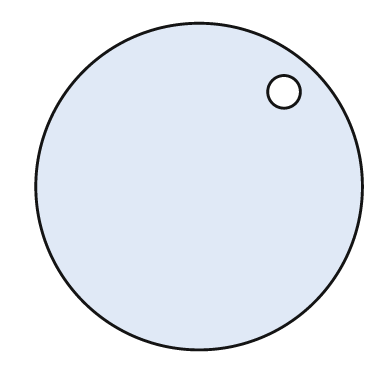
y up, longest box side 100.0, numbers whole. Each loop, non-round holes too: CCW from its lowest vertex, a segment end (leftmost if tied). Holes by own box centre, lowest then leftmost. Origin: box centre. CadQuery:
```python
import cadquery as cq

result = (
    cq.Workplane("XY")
    .moveTo(0.0, 0.0)
    .circle(50.0)
    .moveTo(26.0, 29.0)
    .circle(5.0)
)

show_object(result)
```